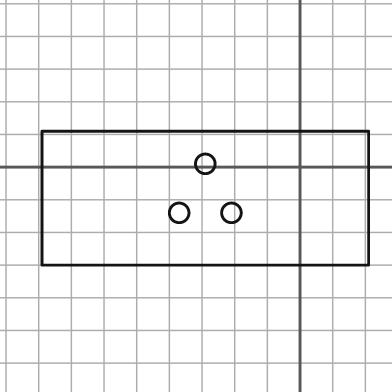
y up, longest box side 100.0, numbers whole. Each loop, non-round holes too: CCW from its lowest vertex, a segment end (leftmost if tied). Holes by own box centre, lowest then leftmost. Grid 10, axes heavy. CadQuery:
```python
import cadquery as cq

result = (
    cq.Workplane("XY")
    .moveTo(-79.0, -30.0)
    .lineTo(21.0, -30.0)
    .lineTo(21.0, 11.0)
    .lineTo(-79.0, 11.0)
    .close()
    .moveTo(-37.0, -14.0)
    .circle(3.0)
    .moveTo(-21.0, -14.0)
    .circle(3.0)
    .moveTo(-29.0, 1.0)
    .circle(3.0)
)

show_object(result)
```